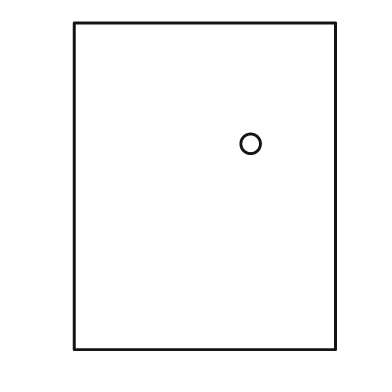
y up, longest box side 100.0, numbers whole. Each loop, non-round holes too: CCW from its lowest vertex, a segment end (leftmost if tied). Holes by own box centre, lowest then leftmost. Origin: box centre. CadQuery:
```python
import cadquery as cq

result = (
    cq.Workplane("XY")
    .moveTo(-40.0, -50.0)
    .lineTo(40.0, -50.0)
    .lineTo(40.0, 50.0)
    .lineTo(-40.0, 50.0)
    .close()
    .moveTo(14.0, 13.0)
    .circle(3.0)
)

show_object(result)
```